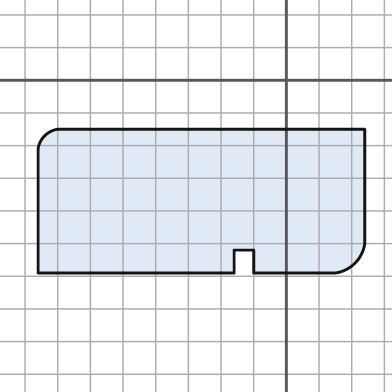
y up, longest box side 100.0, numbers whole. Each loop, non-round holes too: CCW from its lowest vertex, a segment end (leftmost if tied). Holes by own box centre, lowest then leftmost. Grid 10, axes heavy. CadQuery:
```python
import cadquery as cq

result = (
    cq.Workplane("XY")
    .moveTo(-76.0, -59.0)
    .lineTo(-16.0, -59.0)
    .lineTo(-16.0, -52.0)
    .lineTo(-10.0, -52.0)
    .lineTo(-10.0, -59.0)
    .lineTo(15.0, -59.0)
    .threePointArc((21.0, -56.0), (24.0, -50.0))
    .lineTo(24.0, -15.0)
    .lineTo(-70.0, -15.0)
    .threePointArc((-74.0, -17.0), (-76.0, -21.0))
    .close()
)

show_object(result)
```